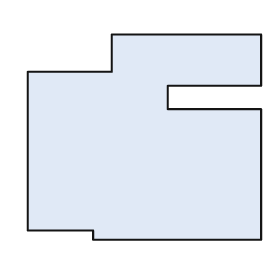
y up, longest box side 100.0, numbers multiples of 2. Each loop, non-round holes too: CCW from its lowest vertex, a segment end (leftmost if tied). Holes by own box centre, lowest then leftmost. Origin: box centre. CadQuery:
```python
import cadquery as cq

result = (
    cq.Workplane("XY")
    .moveTo(-22.0, -44.0)
    .lineTo(50.0, -44.0)
    .lineTo(50.0, 12.0)
    .lineTo(10.0, 12.0)
    .lineTo(10.0, 22.0)
    .lineTo(50.0, 22.0)
    .lineTo(50.0, 44.0)
    .lineTo(-14.0, 44.0)
    .lineTo(-14.0, 28.0)
    .lineTo(-50.0, 28.0)
    .lineTo(-50.0, -40.0)
    .lineTo(-22.0, -40.0)
    .close()
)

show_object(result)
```